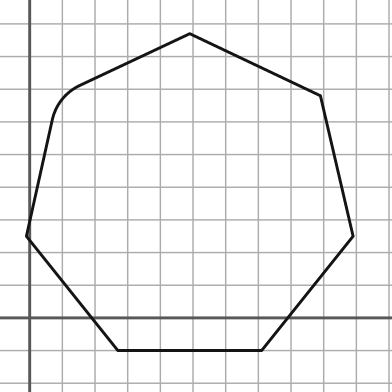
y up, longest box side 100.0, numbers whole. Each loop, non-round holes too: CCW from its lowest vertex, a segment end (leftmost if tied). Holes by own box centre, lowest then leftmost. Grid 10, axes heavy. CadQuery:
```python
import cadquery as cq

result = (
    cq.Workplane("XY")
    .moveTo(27.0, -10.0)
    .lineTo(71.0, -10.0)
    .lineTo(99.0, 25.0)
    .lineTo(89.0, 68.0)
    .lineTo(49.0, 87.0)
    .lineTo(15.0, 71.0)
    .threePointArc((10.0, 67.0), (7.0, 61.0))
    .lineTo(-1.0, 25.0)
    .close()
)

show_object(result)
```